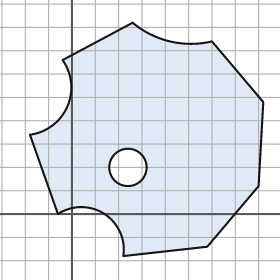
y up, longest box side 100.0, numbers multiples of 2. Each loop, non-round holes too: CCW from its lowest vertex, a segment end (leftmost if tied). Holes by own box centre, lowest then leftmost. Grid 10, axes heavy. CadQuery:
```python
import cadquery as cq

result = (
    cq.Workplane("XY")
    .moveTo(22.0, -18.0)
    .lineTo(58.0, -14.0)
    .lineTo(80.0, 12.0)
    .lineTo(82.0, 48.0)
    .lineTo(60.0, 74.0)
    .threePointArc((42.0, 74.0), (26.0, 82.0))
    .lineTo(-4.0, 66.0)
    .threePointArc((-2.0, 46.0), (-18.0, 34.0))
    .lineTo(-6.0, 0.0)
    .threePointArc((14.0, 0.0), (22.0, -18.0))
    .close()
    .moveTo(24.0, 20.0)
    .circle(8.0)
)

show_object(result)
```